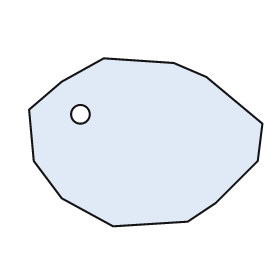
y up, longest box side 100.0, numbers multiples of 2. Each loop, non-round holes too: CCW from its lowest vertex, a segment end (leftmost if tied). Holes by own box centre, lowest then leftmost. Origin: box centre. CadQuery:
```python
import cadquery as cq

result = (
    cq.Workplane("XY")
    .moveTo(-14.0, -36.0)
    .lineTo(18.0, -34.0)
    .lineTo(30.0, -26.0)
    .lineTo(48.0, -8.0)
    .lineTo(50.0, 8.0)
    .lineTo(26.0, 28.0)
    .lineTo(12.0, 34.0)
    .lineTo(-18.0, 36.0)
    .lineTo(-36.0, 26.0)
    .lineTo(-50.0, 14.0)
    .lineTo(-48.0, -8.0)
    .lineTo(-36.0, -24.0)
    .close()
    .moveTo(-28.0, 12.0)
    .circle(4.0)
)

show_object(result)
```